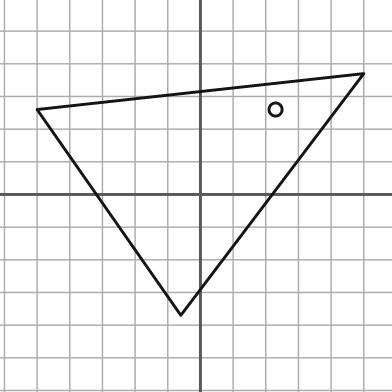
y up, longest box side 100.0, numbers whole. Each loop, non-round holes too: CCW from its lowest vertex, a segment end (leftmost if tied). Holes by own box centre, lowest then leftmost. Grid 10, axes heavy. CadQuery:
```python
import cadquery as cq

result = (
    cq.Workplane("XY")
    .moveTo(-6.0, -37.0)
    .lineTo(50.0, 37.0)
    .lineTo(-50.0, 26.0)
    .close()
    .moveTo(23.0, 26.0)
    .circle(2.0)
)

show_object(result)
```